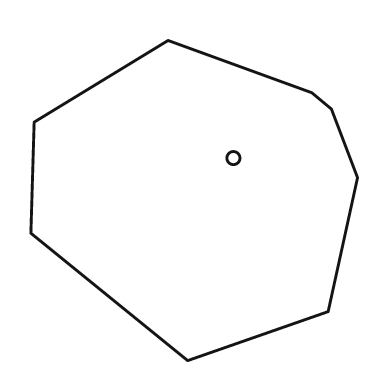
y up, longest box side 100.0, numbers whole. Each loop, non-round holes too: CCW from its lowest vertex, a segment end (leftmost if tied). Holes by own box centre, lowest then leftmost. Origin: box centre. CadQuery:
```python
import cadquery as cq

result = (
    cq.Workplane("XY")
    .moveTo(-2.0, -49.0)
    .lineTo(41.0, -34.0)
    .lineTo(50.0, 7.0)
    .lineTo(42.0, 28.0)
    .lineTo(36.0, 33.0)
    .lineTo(-8.0, 49.0)
    .lineTo(-49.0, 24.0)
    .lineTo(-50.0, -10.0)
    .close()
    .moveTo(12.0, 13.0)
    .circle(2.0)
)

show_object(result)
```